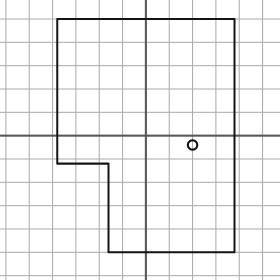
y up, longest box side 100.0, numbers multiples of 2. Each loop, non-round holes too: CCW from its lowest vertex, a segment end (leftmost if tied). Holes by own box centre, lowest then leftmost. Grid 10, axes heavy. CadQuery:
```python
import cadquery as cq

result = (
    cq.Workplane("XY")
    .moveTo(-16.0, -50.0)
    .lineTo(38.0, -50.0)
    .lineTo(38.0, 50.0)
    .lineTo(-38.0, 50.0)
    .lineTo(-38.0, -12.0)
    .lineTo(-16.0, -12.0)
    .close()
    .moveTo(20.0, -4.0)
    .circle(2.0)
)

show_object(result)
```